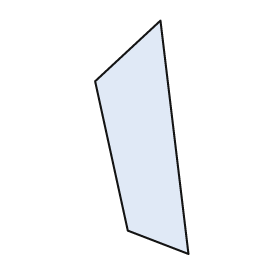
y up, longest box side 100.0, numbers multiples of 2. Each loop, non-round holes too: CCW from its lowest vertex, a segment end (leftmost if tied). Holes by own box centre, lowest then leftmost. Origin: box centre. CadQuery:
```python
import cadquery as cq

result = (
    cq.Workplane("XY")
    .moveTo(20.0, -50.0)
    .lineTo(8.0, 50.0)
    .lineTo(-20.0, 24.0)
    .lineTo(-6.0, -40.0)
    .close()
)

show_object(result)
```